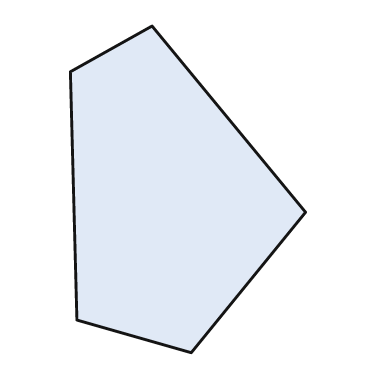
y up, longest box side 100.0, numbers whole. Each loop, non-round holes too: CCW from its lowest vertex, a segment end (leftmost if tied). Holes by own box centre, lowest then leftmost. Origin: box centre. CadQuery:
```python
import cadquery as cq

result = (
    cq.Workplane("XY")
    .moveTo(1.0, -50.0)
    .lineTo(36.0, -7.0)
    .lineTo(-11.0, 50.0)
    .lineTo(-36.0, 36.0)
    .lineTo(-34.0, -40.0)
    .close()
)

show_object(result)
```